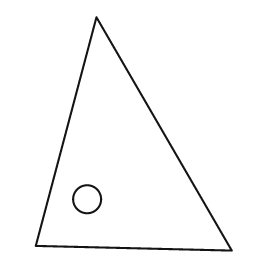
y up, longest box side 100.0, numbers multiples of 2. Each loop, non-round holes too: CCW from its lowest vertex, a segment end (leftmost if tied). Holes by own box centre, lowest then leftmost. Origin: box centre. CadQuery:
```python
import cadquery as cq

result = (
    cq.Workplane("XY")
    .moveTo(42.0, -50.0)
    .lineTo(-16.0, 50.0)
    .lineTo(-42.0, -48.0)
    .close()
    .moveTo(-20.0, -28.0)
    .circle(6.0)
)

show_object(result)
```